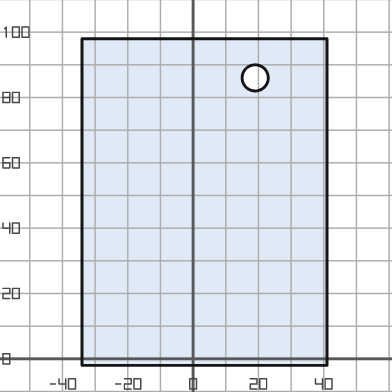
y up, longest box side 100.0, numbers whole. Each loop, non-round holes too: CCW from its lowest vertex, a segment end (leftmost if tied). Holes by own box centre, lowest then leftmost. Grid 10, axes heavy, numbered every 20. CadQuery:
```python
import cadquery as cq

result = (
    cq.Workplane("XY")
    .moveTo(-34.0, -2.0)
    .lineTo(41.0, -2.0)
    .lineTo(41.0, 98.0)
    .lineTo(-34.0, 98.0)
    .close()
    .moveTo(19.0, 86.0)
    .circle(4.0)
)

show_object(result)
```